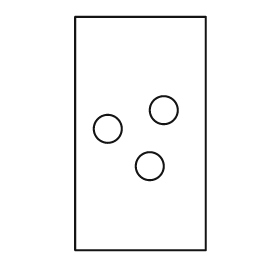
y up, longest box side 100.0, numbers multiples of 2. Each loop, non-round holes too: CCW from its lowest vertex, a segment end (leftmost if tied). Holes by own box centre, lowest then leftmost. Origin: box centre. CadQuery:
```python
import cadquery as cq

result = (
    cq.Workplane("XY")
    .moveTo(-28.0, -50.0)
    .lineTo(28.0, -50.0)
    .lineTo(28.0, 50.0)
    .lineTo(-28.0, 50.0)
    .close()
    .moveTo(4.0, -14.0)
    .circle(6.0)
    .moveTo(-14.0, 2.0)
    .circle(6.0)
    .moveTo(10.0, 10.0)
    .circle(6.0)
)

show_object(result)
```